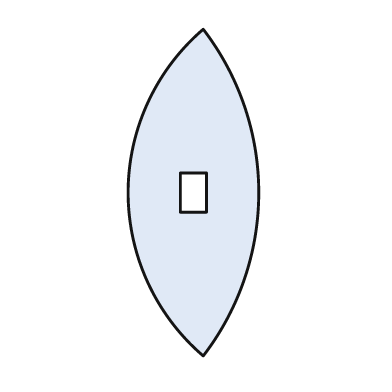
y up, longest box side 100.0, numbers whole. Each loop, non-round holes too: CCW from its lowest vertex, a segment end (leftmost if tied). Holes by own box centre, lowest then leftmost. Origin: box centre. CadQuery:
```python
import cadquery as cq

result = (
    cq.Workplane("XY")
    .moveTo(3.0, -50.0)
    .threePointArc((20.0, 0.0), (3.0, 50.0))
    .threePointArc((-20.0, 0.0), (3.0, -50.0))
    .close()
    .moveTo(-4.0, -6.0)
    .lineTo(4.0, -6.0)
    .lineTo(4.0, 6.0)
    .lineTo(-4.0, 6.0)
    .close()
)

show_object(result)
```